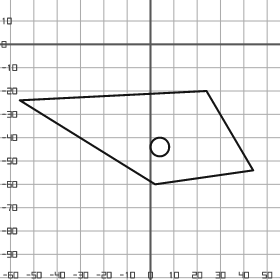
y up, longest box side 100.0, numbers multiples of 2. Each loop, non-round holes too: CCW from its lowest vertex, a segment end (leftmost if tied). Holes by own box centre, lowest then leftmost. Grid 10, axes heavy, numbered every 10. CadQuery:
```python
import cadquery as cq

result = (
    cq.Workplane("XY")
    .moveTo(2.0, -60.0)
    .lineTo(44.0, -54.0)
    .lineTo(24.0, -20.0)
    .lineTo(-56.0, -24.0)
    .close()
    .moveTo(4.0, -44.0)
    .circle(4.0)
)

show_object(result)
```